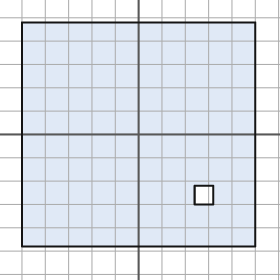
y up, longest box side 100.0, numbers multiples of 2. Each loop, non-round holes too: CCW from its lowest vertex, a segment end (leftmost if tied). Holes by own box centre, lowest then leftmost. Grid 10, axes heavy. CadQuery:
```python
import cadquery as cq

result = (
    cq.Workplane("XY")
    .moveTo(-50.0, -48.0)
    .lineTo(50.0, -48.0)
    .lineTo(50.0, 48.0)
    .lineTo(-50.0, 48.0)
    .close()
    .moveTo(24.0, -30.0)
    .lineTo(32.0, -30.0)
    .lineTo(32.0, -22.0)
    .lineTo(24.0, -22.0)
    .close()
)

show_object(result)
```